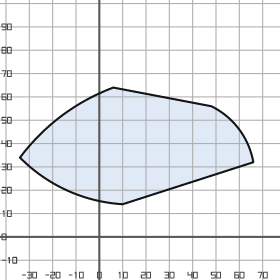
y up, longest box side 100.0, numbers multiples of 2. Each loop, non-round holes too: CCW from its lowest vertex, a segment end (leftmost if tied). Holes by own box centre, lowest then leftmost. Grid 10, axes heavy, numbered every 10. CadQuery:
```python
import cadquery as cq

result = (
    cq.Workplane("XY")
    .moveTo(10.0, 14.0)
    .lineTo(66.0, 32.0)
    .threePointArc((60.0, 46.0), (48.0, 56.0))
    .lineTo(6.0, 64.0)
    .threePointArc((-16.0, 52.0), (-34.0, 34.0))
    .threePointArc((-14.0, 20.0), (10.0, 14.0))
    .close()
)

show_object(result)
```